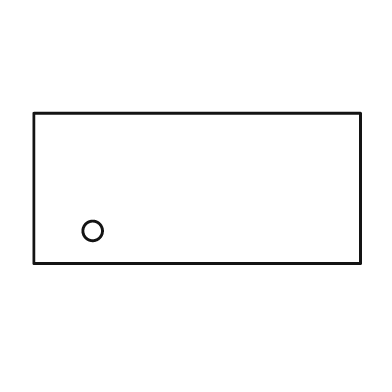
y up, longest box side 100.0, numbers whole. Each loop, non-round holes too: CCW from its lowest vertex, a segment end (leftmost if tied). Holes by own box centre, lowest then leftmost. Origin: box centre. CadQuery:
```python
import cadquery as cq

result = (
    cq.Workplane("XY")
    .moveTo(-50.0, -23.0)
    .lineTo(50.0, -23.0)
    .lineTo(50.0, 23.0)
    .lineTo(-50.0, 23.0)
    .close()
    .moveTo(-32.0, -13.0)
    .circle(3.0)
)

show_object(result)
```